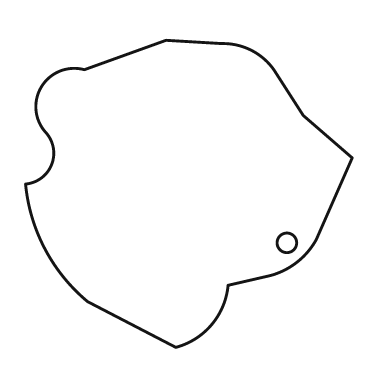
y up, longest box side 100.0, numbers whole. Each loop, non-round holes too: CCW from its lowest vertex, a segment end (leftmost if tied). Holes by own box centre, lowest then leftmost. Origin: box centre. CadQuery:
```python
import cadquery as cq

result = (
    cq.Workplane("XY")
    .moveTo(-4.0, -47.0)
    .threePointArc((7.0, -40.0), (12.0, -28.0))
    .lineTo(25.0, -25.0)
    .threePointArc((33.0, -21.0), (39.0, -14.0))
    .lineTo(50.0, 11.0)
    .lineTo(35.0, 24.0)
    .lineTo(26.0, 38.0)
    .threePointArc((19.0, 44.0), (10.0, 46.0))
    .lineTo(-7.0, 47.0)
    .lineTo(-32.0, 38.0)
    .threePointArc((-45.0, 33.0), (-44.0, 19.0))
    .threePointArc((-42.0, 9.0), (-50.0, 3.0))
    .threePointArc((-44.0, -17.0), (-31.0, -33.0))
    .close()
    .moveTo(30.0, -15.0)
    .circle(3.0)
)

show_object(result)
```